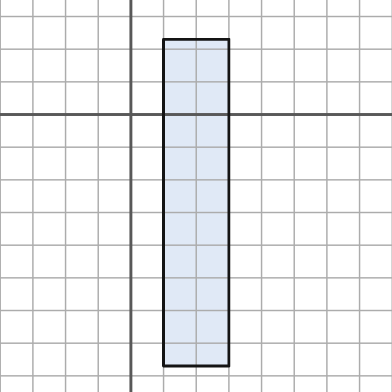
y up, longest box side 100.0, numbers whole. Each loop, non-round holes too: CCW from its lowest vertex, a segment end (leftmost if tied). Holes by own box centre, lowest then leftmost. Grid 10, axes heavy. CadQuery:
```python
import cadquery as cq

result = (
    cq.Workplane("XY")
    .moveTo(10.0, -77.0)
    .lineTo(30.0, -77.0)
    .lineTo(30.0, 23.0)
    .lineTo(10.0, 23.0)
    .close()
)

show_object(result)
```